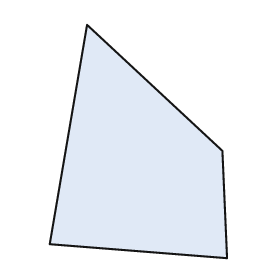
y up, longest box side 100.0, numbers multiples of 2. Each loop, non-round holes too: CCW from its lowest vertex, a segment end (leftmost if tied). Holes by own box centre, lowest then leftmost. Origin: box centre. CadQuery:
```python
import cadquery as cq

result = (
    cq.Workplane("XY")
    .moveTo(38.0, -50.0)
    .lineTo(36.0, -4.0)
    .lineTo(-22.0, 50.0)
    .lineTo(-38.0, -44.0)
    .close()
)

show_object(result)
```